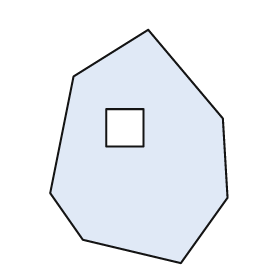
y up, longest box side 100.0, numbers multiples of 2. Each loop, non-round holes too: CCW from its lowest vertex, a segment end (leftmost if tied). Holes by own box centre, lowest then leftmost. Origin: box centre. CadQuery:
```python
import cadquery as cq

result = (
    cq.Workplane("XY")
    .moveTo(18.0, -50.0)
    .lineTo(38.0, -22.0)
    .lineTo(36.0, 12.0)
    .lineTo(4.0, 50.0)
    .lineTo(-28.0, 30.0)
    .lineTo(-38.0, -20.0)
    .lineTo(-24.0, -40.0)
    .close()
    .moveTo(-14.0, 0.0)
    .lineTo(2.0, 0.0)
    .lineTo(2.0, 16.0)
    .lineTo(-14.0, 16.0)
    .close()
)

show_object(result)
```